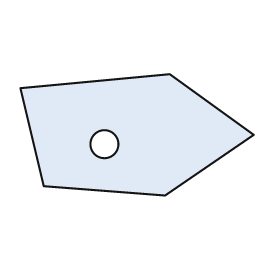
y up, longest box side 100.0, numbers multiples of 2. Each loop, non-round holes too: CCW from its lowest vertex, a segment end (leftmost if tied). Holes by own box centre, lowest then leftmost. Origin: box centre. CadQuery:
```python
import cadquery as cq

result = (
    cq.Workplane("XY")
    .moveTo(12.0, -26.0)
    .lineTo(50.0, 0.0)
    .lineTo(14.0, 26.0)
    .lineTo(-50.0, 20.0)
    .lineTo(-40.0, -22.0)
    .close()
    .moveTo(-14.0, -4.0)
    .circle(6.0)
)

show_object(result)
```